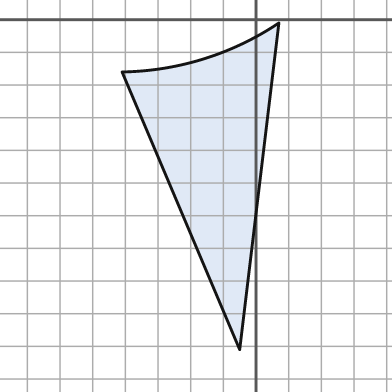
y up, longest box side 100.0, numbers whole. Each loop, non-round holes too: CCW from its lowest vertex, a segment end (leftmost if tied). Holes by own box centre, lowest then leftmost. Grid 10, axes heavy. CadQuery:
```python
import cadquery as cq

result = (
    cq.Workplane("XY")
    .moveTo(-5.0, -101.0)
    .lineTo(7.0, -1.0)
    .threePointArc((-16.0, -12.0), (-41.0, -16.0))
    .close()
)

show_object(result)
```